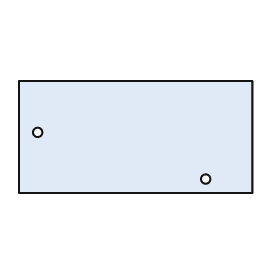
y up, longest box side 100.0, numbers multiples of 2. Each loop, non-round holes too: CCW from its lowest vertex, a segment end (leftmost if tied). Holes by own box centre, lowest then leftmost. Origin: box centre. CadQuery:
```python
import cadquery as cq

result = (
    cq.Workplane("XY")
    .moveTo(-50.0, -24.0)
    .lineTo(50.0, -24.0)
    .lineTo(50.0, 24.0)
    .lineTo(-50.0, 24.0)
    .close()
    .moveTo(30.0, -18.0)
    .circle(2.0)
    .moveTo(-42.0, 2.0)
    .circle(2.0)
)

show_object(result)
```